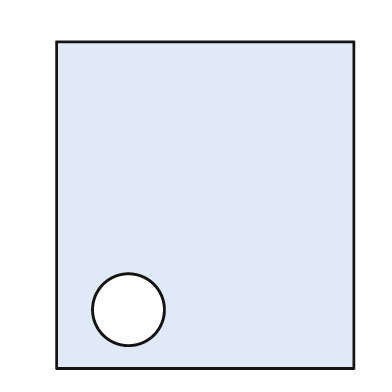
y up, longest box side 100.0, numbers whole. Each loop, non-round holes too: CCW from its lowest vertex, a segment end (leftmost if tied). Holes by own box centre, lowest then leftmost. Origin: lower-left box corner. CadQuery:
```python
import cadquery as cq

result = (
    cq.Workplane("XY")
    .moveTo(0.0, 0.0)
    .lineTo(91.0, 0.0)
    .lineTo(91.0, 100.0)
    .lineTo(0.0, 100.0)
    .close()
    .moveTo(22.0, 18.0)
    .circle(11.0)
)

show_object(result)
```